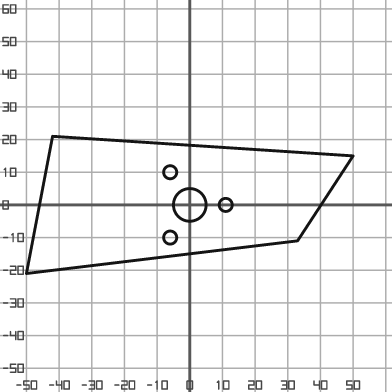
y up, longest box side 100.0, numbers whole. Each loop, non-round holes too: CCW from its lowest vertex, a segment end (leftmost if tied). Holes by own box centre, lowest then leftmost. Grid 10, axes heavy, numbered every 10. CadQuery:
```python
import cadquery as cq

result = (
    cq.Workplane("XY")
    .moveTo(-50.0, -21.0)
    .lineTo(33.0, -11.0)
    .lineTo(50.0, 15.0)
    .lineTo(-42.0, 21.0)
    .close()
    .moveTo(-6.0, -10.0)
    .circle(2.0)
    .moveTo(0.0, 0.0)
    .circle(5.0)
    .moveTo(11.0, 0.0)
    .circle(2.0)
    .moveTo(-6.0, 10.0)
    .circle(2.0)
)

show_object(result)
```